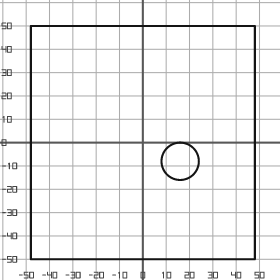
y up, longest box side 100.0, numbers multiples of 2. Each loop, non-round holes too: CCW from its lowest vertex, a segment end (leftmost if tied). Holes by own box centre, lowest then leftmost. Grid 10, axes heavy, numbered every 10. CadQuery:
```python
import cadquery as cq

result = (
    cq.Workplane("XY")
    .moveTo(-48.0, -50.0)
    .lineTo(48.0, -50.0)
    .lineTo(48.0, 50.0)
    .lineTo(-48.0, 50.0)
    .close()
    .moveTo(16.0, -8.0)
    .circle(8.0)
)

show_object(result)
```